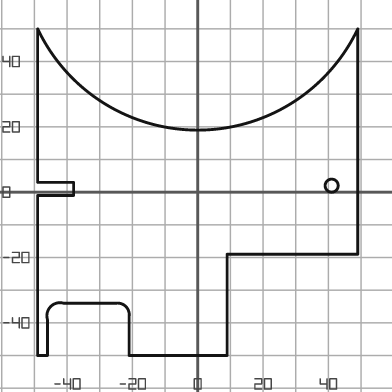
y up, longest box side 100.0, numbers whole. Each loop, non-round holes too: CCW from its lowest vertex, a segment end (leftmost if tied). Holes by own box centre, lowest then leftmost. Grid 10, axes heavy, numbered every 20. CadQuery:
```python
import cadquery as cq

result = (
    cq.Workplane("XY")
    .moveTo(-49.0, -50.0)
    .lineTo(-46.0, -50.0)
    .lineTo(-46.0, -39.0)
    .threePointArc((-45.0, -35.0), (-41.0, -34.0))
    .lineTo(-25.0, -34.0)
    .threePointArc((-22.0, -35.0), (-21.0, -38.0))
    .lineTo(-21.0, -50.0)
    .lineTo(9.0, -50.0)
    .lineTo(9.0, -19.0)
    .lineTo(49.0, -19.0)
    .lineTo(49.0, 50.0)
    .threePointArc((0.0, 19.0), (-49.0, 50.0))
    .lineTo(-49.0, 3.0)
    .lineTo(-38.0, 3.0)
    .lineTo(-38.0, -1.0)
    .lineTo(-49.0, -1.0)
    .close()
    .moveTo(41.0, 2.0)
    .circle(2.0)
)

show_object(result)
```